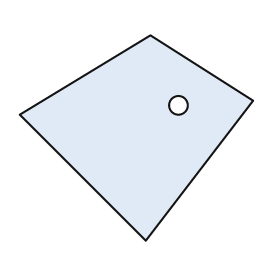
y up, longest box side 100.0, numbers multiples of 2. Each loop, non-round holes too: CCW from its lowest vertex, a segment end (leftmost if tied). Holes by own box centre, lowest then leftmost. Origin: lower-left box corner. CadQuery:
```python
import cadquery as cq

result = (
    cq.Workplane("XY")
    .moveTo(54.0, 0.0)
    .lineTo(100.0, 60.0)
    .lineTo(56.0, 88.0)
    .lineTo(0.0, 54.0)
    .close()
    .moveTo(68.0, 58.0)
    .circle(4.0)
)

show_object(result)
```